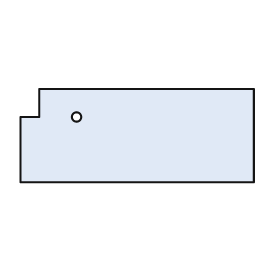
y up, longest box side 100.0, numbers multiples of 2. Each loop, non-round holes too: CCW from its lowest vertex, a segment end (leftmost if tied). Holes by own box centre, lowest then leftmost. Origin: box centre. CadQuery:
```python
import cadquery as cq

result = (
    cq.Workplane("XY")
    .moveTo(-50.0, -20.0)
    .lineTo(50.0, -20.0)
    .lineTo(50.0, 20.0)
    .lineTo(-42.0, 20.0)
    .lineTo(-42.0, 8.0)
    .lineTo(-50.0, 8.0)
    .close()
    .moveTo(-26.0, 8.0)
    .circle(2.0)
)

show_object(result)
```